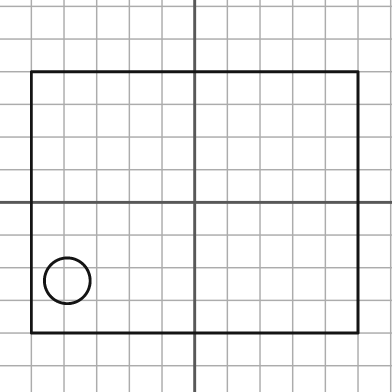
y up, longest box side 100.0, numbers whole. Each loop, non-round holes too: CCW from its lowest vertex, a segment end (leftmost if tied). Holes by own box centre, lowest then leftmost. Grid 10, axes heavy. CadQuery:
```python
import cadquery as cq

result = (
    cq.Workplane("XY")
    .moveTo(-50.0, -40.0)
    .lineTo(50.0, -40.0)
    .lineTo(50.0, 40.0)
    .lineTo(-50.0, 40.0)
    .close()
    .moveTo(-39.0, -24.0)
    .circle(7.0)
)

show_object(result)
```